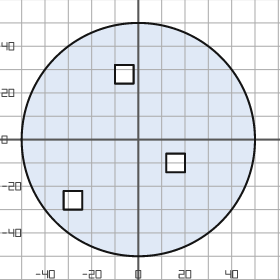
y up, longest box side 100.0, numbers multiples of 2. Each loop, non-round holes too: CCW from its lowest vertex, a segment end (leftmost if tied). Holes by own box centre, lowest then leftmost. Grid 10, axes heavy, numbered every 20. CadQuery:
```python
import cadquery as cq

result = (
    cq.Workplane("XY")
    .moveTo(0.0, 0.0)
    .circle(50.0)
    .moveTo(-32.0, -30.0)
    .lineTo(-24.0, -30.0)
    .lineTo(-24.0, -22.0)
    .lineTo(-32.0, -22.0)
    .close()
    .moveTo(12.0, -14.0)
    .lineTo(20.0, -14.0)
    .lineTo(20.0, -6.0)
    .lineTo(12.0, -6.0)
    .close()
    .moveTo(-10.0, 24.0)
    .lineTo(-2.0, 24.0)
    .lineTo(-2.0, 32.0)
    .lineTo(-10.0, 32.0)
    .close()
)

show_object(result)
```